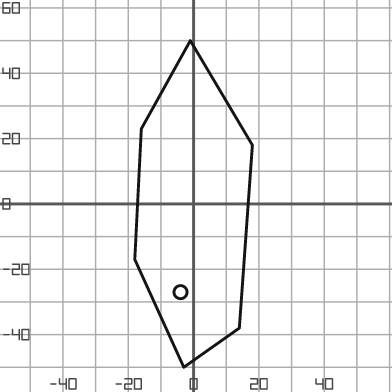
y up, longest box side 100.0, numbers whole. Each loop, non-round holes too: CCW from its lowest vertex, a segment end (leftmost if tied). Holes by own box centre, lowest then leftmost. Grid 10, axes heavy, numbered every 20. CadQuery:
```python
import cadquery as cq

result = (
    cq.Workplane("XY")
    .moveTo(-3.0, -50.0)
    .lineTo(14.0, -38.0)
    .lineTo(18.0, 18.0)
    .lineTo(-1.0, 50.0)
    .lineTo(-16.0, 23.0)
    .lineTo(-18.0, -17.0)
    .close()
    .moveTo(-4.0, -27.0)
    .circle(2.0)
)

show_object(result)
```